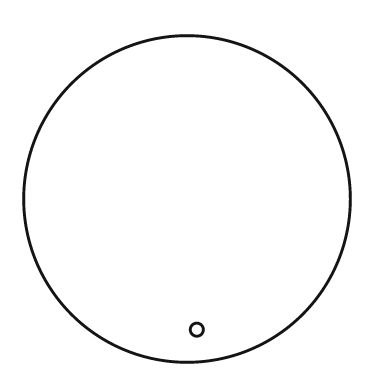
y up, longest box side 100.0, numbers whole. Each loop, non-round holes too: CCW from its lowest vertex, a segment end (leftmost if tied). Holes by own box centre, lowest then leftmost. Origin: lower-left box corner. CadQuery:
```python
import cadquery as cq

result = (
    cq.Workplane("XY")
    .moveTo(50.0, 50.0)
    .circle(50.0)
    .moveTo(53.0, 10.0)
    .circle(2.0)
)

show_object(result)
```